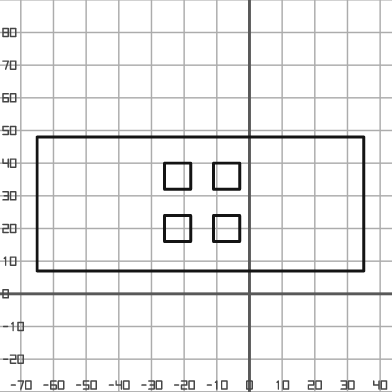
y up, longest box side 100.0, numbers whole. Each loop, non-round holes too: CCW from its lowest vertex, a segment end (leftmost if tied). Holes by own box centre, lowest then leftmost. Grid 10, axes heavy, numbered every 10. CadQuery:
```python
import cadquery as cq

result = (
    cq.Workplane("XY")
    .moveTo(-65.0, 7.0)
    .lineTo(35.0, 7.0)
    .lineTo(35.0, 48.0)
    .lineTo(-65.0, 48.0)
    .close()
    .moveTo(-26.0, 16.0)
    .lineTo(-18.0, 16.0)
    .lineTo(-18.0, 24.0)
    .lineTo(-26.0, 24.0)
    .close()
    .moveTo(-11.0, 16.0)
    .lineTo(-3.0, 16.0)
    .lineTo(-3.0, 24.0)
    .lineTo(-11.0, 24.0)
    .close()
    .moveTo(-26.0, 32.0)
    .lineTo(-18.0, 32.0)
    .lineTo(-18.0, 40.0)
    .lineTo(-26.0, 40.0)
    .close()
    .moveTo(-11.0, 32.0)
    .lineTo(-3.0, 32.0)
    .lineTo(-3.0, 40.0)
    .lineTo(-11.0, 40.0)
    .close()
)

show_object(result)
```